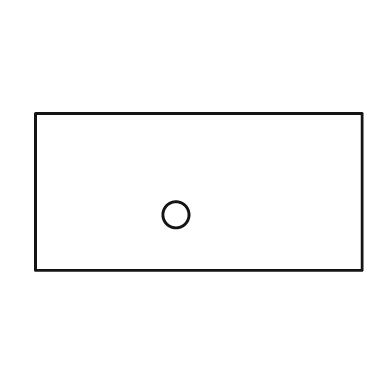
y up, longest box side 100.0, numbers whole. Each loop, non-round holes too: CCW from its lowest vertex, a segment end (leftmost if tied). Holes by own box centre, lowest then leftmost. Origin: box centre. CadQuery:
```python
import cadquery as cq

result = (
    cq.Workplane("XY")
    .moveTo(-50.0, -24.0)
    .lineTo(50.0, -24.0)
    .lineTo(50.0, 24.0)
    .lineTo(-50.0, 24.0)
    .close()
    .moveTo(-7.0, -7.0)
    .circle(4.0)
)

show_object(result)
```